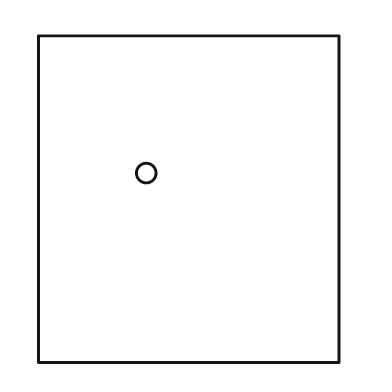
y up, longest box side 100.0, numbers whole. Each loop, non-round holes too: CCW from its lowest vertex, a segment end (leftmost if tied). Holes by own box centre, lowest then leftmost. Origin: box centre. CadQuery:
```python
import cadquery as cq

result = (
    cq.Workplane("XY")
    .moveTo(-46.0, -50.0)
    .lineTo(46.0, -50.0)
    .lineTo(46.0, 50.0)
    .lineTo(-46.0, 50.0)
    .close()
    .moveTo(-13.0, 8.0)
    .circle(3.0)
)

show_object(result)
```